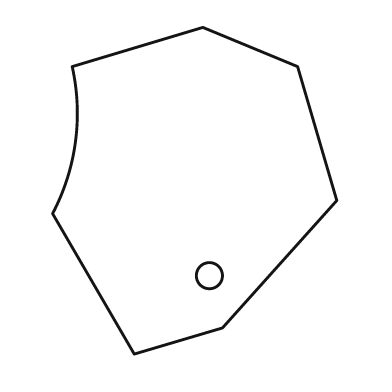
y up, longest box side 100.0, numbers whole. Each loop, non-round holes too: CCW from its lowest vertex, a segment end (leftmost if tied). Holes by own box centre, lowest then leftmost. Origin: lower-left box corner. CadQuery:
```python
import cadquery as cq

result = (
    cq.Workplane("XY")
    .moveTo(25.0, 0.0)
    .lineTo(52.0, 8.0)
    .lineTo(87.0, 47.0)
    .lineTo(75.0, 88.0)
    .lineTo(46.0, 100.0)
    .lineTo(6.0, 88.0)
    .threePointArc((7.0, 65.0), (0.0, 43.0))
    .close()
    .moveTo(48.0, 24.0)
    .circle(4.0)
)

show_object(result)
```